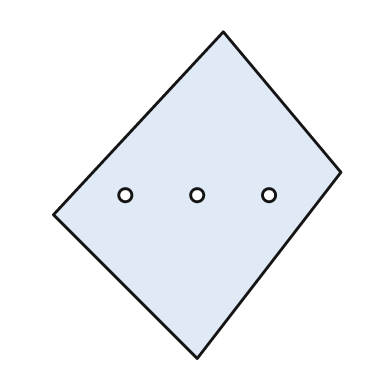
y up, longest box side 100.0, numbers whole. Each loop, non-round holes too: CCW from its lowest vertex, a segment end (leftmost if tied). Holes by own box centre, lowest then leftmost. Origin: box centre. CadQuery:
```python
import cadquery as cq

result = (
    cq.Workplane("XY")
    .moveTo(0.0, -50.0)
    .lineTo(44.0, 7.0)
    .lineTo(8.0, 50.0)
    .lineTo(-44.0, -6.0)
    .close()
    .moveTo(-22.0, 0.0)
    .circle(2.0)
    .moveTo(0.0, 0.0)
    .circle(2.0)
    .moveTo(22.0, 0.0)
    .circle(2.0)
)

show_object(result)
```